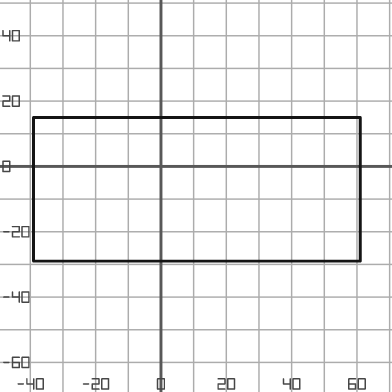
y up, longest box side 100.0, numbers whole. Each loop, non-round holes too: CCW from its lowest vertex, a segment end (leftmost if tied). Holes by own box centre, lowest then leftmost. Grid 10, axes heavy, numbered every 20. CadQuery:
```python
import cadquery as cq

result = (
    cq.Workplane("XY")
    .moveTo(-39.0, -29.0)
    .lineTo(61.0, -29.0)
    .lineTo(61.0, 15.0)
    .lineTo(-39.0, 15.0)
    .close()
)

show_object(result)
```